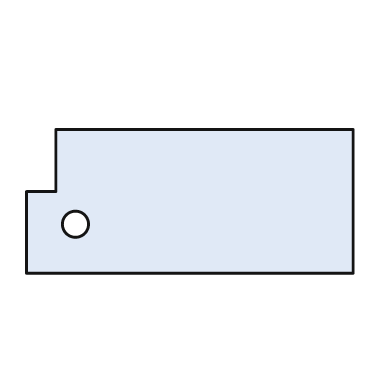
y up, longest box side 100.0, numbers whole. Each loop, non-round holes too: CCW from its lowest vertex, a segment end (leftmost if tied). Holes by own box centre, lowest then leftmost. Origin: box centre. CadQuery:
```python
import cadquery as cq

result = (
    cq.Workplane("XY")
    .moveTo(-50.0, -22.0)
    .lineTo(50.0, -22.0)
    .lineTo(50.0, 22.0)
    .lineTo(-41.0, 22.0)
    .lineTo(-41.0, 3.0)
    .lineTo(-50.0, 3.0)
    .close()
    .moveTo(-35.0, -7.0)
    .circle(4.0)
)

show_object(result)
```